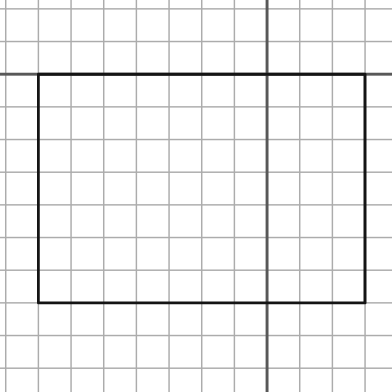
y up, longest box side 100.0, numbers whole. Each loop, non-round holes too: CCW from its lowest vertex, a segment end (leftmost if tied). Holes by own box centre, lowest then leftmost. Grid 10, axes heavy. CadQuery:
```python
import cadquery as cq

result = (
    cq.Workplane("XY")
    .moveTo(-70.0, -70.0)
    .lineTo(30.0, -70.0)
    .lineTo(30.0, 0.0)
    .lineTo(-70.0, 0.0)
    .close()
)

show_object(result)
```